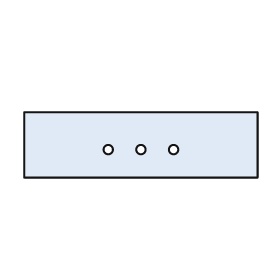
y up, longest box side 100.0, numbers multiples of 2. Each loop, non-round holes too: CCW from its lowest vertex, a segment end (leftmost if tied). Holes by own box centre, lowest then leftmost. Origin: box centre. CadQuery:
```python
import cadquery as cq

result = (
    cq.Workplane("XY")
    .moveTo(-50.0, -14.0)
    .lineTo(50.0, -14.0)
    .lineTo(50.0, 14.0)
    .lineTo(-50.0, 14.0)
    .close()
    .moveTo(-14.0, -2.0)
    .circle(2.0)
    .moveTo(0.0, -2.0)
    .circle(2.0)
    .moveTo(14.0, -2.0)
    .circle(2.0)
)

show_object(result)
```